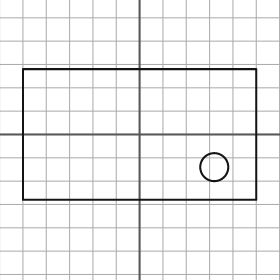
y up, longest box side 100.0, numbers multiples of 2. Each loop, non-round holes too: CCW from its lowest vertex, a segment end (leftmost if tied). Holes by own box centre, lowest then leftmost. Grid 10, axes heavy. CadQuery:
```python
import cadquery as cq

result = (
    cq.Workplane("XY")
    .moveTo(-50.0, -28.0)
    .lineTo(50.0, -28.0)
    .lineTo(50.0, 28.0)
    .lineTo(-50.0, 28.0)
    .close()
    .moveTo(32.0, -14.0)
    .circle(6.0)
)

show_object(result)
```